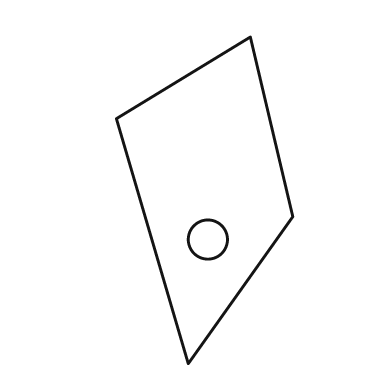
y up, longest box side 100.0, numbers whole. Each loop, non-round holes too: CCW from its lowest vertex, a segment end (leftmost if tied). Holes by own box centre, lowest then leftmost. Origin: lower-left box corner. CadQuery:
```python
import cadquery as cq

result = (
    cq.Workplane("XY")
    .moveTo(22.0, 0.0)
    .lineTo(54.0, 45.0)
    .lineTo(41.0, 100.0)
    .lineTo(0.0, 75.0)
    .close()
    .moveTo(28.0, 38.0)
    .circle(6.0)
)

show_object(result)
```